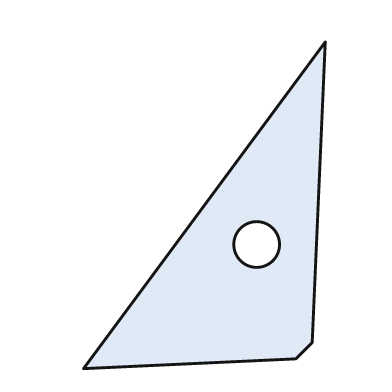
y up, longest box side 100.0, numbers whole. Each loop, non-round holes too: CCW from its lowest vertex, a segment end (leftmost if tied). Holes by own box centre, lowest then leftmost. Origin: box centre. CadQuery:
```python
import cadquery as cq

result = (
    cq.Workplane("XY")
    .moveTo(-37.0, -50.0)
    .lineTo(28.0, -47.0)
    .lineTo(33.0, -42.0)
    .lineTo(37.0, 50.0)
    .close()
    .moveTo(16.0, -12.0)
    .circle(7.0)
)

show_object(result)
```